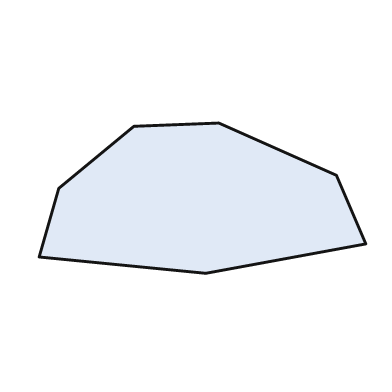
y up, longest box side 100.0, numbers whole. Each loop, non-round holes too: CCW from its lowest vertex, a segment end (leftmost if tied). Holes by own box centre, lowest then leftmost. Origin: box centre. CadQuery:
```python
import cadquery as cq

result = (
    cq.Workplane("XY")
    .moveTo(1.0, -23.0)
    .lineTo(50.0, -14.0)
    .lineTo(41.0, 7.0)
    .lineTo(5.0, 23.0)
    .lineTo(-21.0, 22.0)
    .lineTo(-44.0, 3.0)
    .lineTo(-50.0, -18.0)
    .close()
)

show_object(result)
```